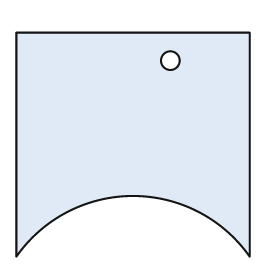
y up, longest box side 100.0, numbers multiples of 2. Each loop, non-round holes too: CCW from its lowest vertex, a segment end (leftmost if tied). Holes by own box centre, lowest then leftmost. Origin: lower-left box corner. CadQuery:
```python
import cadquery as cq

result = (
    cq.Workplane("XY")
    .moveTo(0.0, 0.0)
    .threePointArc((50.0, 26.0), (100.0, 0.0))
    .lineTo(100.0, 96.0)
    .lineTo(0.0, 96.0)
    .close()
    .moveTo(66.0, 84.0)
    .circle(4.0)
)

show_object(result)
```